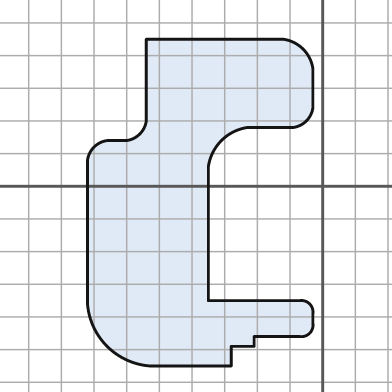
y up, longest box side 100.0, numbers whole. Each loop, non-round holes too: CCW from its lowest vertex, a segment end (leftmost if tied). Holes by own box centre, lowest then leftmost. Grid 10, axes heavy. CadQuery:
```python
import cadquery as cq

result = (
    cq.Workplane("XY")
    .moveTo(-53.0, -55.0)
    .lineTo(-28.0, -55.0)
    .lineTo(-28.0, -49.0)
    .lineTo(-21.0, -49.0)
    .lineTo(-21.0, -46.0)
    .lineTo(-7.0, -46.0)
    .threePointArc((-4.0, -45.0), (-3.0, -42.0))
    .lineTo(-3.0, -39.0)
    .threePointArc((-4.0, -36.0), (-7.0, -35.0))
    .lineTo(-35.0, -35.0)
    .lineTo(-35.0, 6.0)
    .threePointArc((-31.0, 14.0), (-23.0, 18.0))
    .lineTo(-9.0, 18.0)
    .threePointArc((-5.0, 20.0), (-3.0, 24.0))
    .lineTo(-3.0, 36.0)
    .threePointArc((-6.0, 42.0), (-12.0, 45.0))
    .lineTo(-54.0, 45.0)
    .lineTo(-54.0, 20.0)
    .threePointArc((-56.0, 16.0), (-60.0, 14.0))
    .lineTo(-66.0, 14.0)
    .threePointArc((-70.0, 12.0), (-72.0, 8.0))
    .lineTo(-72.0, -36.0)
    .threePointArc((-66.0, -49.0), (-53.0, -55.0))
    .close()
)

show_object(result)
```